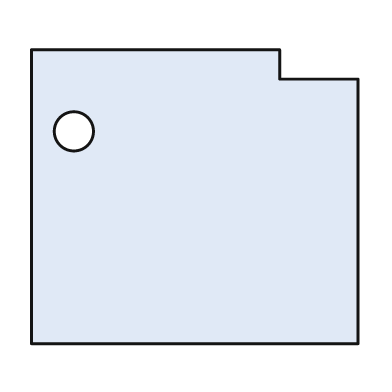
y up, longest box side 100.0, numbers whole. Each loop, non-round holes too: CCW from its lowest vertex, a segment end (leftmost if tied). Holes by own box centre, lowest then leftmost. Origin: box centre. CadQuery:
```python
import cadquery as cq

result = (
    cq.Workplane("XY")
    .moveTo(-50.0, -45.0)
    .lineTo(50.0, -45.0)
    .lineTo(50.0, 36.0)
    .lineTo(26.0, 36.0)
    .lineTo(26.0, 45.0)
    .lineTo(-50.0, 45.0)
    .close()
    .moveTo(-37.0, 20.0)
    .circle(6.0)
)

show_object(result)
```